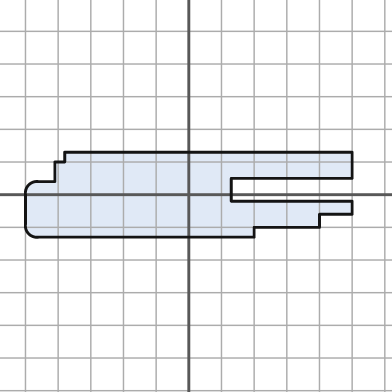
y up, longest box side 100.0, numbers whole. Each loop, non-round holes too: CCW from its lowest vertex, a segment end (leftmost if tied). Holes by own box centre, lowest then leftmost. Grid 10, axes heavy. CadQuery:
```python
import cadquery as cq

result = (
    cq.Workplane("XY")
    .moveTo(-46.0, -13.0)
    .lineTo(20.0, -13.0)
    .lineTo(20.0, -10.0)
    .lineTo(40.0, -10.0)
    .lineTo(40.0, -6.0)
    .lineTo(50.0, -6.0)
    .lineTo(50.0, -2.0)
    .lineTo(13.0, -2.0)
    .lineTo(13.0, 5.0)
    .lineTo(50.0, 5.0)
    .lineTo(50.0, 13.0)
    .lineTo(-38.0, 13.0)
    .lineTo(-38.0, 10.0)
    .lineTo(-41.0, 10.0)
    .lineTo(-41.0, 4.0)
    .lineTo(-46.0, 4.0)
    .threePointArc((-49.0, 3.0), (-50.0, 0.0))
    .lineTo(-50.0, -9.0)
    .threePointArc((-49.0, -12.0), (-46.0, -13.0))
    .close()
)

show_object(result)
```